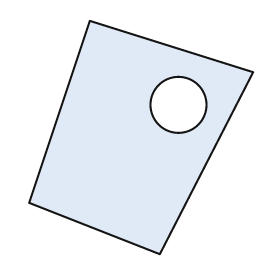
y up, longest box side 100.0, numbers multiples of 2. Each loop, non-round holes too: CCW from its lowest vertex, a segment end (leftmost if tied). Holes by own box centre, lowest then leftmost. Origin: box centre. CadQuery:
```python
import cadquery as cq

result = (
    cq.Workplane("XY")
    .moveTo(8.0, -50.0)
    .lineTo(48.0, 28.0)
    .lineTo(-22.0, 50.0)
    .lineTo(-48.0, -28.0)
    .close()
    .moveTo(16.0, 14.0)
    .circle(12.0)
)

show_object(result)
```